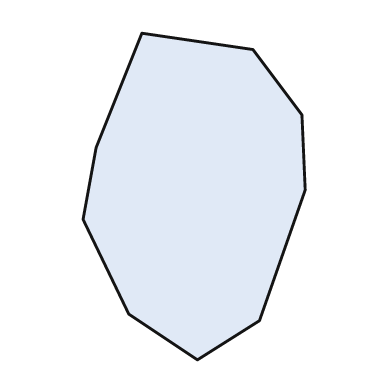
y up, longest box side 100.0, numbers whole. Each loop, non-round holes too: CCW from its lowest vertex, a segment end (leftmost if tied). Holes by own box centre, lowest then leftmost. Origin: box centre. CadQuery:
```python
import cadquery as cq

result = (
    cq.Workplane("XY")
    .moveTo(1.0, -50.0)
    .lineTo(20.0, -38.0)
    .lineTo(34.0, 2.0)
    .lineTo(33.0, 25.0)
    .lineTo(18.0, 45.0)
    .lineTo(-16.0, 50.0)
    .lineTo(-30.0, 15.0)
    .lineTo(-34.0, -7.0)
    .lineTo(-20.0, -36.0)
    .close()
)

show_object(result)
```